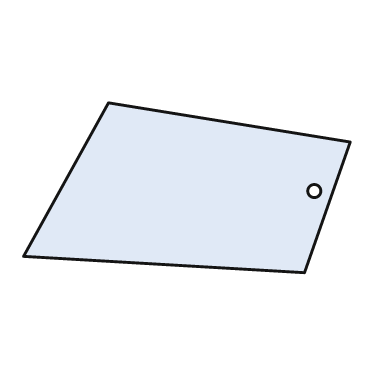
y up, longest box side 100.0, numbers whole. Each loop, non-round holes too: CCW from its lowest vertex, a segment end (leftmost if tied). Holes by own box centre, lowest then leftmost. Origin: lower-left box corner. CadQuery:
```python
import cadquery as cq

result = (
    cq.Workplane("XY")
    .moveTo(86.0, 0.0)
    .lineTo(100.0, 40.0)
    .lineTo(26.0, 52.0)
    .lineTo(0.0, 5.0)
    .close()
    .moveTo(89.0, 25.0)
    .circle(2.0)
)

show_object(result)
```